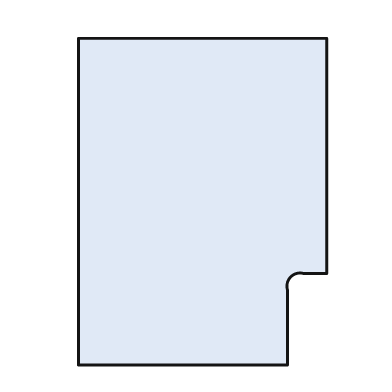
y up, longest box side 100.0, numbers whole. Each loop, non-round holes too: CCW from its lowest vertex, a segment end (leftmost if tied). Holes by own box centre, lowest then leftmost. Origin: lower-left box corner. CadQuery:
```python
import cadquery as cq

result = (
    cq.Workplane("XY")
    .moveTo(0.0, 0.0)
    .lineTo(64.0, 0.0)
    .lineTo(64.0, 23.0)
    .threePointArc((65.0, 27.0), (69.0, 28.0))
    .lineTo(76.0, 28.0)
    .lineTo(76.0, 100.0)
    .lineTo(0.0, 100.0)
    .close()
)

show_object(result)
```